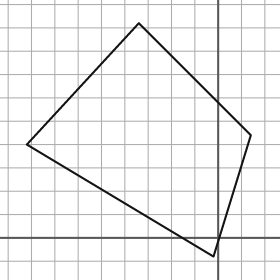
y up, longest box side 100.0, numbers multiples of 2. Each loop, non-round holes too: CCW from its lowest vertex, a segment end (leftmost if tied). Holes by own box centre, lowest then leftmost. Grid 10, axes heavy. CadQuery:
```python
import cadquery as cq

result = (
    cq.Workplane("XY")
    .moveTo(-2.0, -8.0)
    .lineTo(14.0, 44.0)
    .lineTo(-34.0, 92.0)
    .lineTo(-82.0, 40.0)
    .close()
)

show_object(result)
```